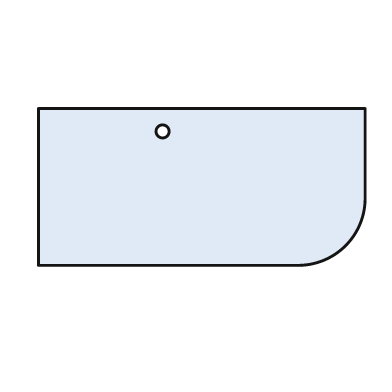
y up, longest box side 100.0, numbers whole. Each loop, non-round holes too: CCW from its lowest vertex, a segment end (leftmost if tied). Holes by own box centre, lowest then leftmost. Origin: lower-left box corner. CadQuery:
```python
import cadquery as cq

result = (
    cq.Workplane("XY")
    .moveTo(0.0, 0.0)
    .lineTo(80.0, 0.0)
    .threePointArc((94.0, 6.0), (100.0, 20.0))
    .lineTo(100.0, 48.0)
    .lineTo(0.0, 48.0)
    .close()
    .moveTo(38.0, 41.0)
    .circle(2.0)
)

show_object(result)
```